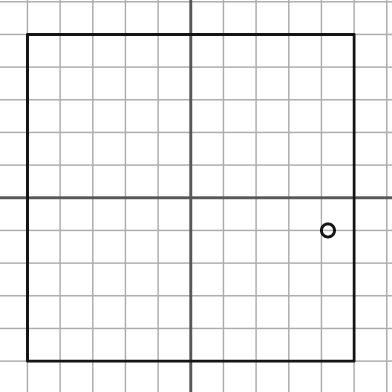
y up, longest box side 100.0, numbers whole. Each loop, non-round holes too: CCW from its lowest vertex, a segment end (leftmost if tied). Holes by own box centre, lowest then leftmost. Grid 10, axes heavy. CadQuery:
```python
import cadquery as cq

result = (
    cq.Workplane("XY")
    .moveTo(-50.0, -50.0)
    .lineTo(50.0, -50.0)
    .lineTo(50.0, 50.0)
    .lineTo(-50.0, 50.0)
    .close()
    .moveTo(42.0, -10.0)
    .circle(2.0)
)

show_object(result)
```